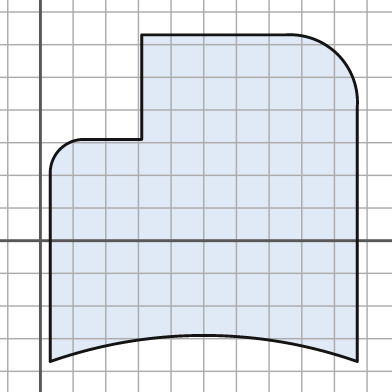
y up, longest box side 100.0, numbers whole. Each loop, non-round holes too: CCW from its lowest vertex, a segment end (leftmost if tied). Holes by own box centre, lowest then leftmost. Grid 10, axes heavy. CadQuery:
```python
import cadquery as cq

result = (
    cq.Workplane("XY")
    .moveTo(3.0, -37.0)
    .threePointArc((50.0, -29.0), (97.0, -37.0))
    .lineTo(97.0, 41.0)
    .threePointArc((91.0, 57.0), (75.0, 63.0))
    .lineTo(31.0, 63.0)
    .lineTo(31.0, 31.0)
    .lineTo(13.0, 31.0)
    .threePointArc((6.0, 28.0), (3.0, 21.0))
    .close()
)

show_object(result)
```